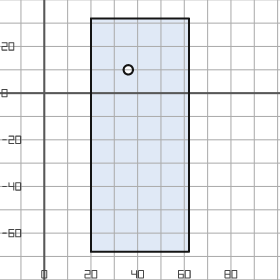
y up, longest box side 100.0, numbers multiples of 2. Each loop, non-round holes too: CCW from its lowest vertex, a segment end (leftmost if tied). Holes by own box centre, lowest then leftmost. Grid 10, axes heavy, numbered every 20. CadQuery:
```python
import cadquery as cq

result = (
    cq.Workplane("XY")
    .moveTo(20.0, -68.0)
    .lineTo(62.0, -68.0)
    .lineTo(62.0, 32.0)
    .lineTo(20.0, 32.0)
    .close()
    .moveTo(36.0, 10.0)
    .circle(2.0)
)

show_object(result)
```